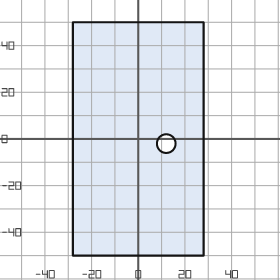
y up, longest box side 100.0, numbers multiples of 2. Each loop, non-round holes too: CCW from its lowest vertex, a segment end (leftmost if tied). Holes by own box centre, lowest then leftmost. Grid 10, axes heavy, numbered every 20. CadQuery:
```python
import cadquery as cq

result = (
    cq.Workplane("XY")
    .moveTo(-28.0, -50.0)
    .lineTo(28.0, -50.0)
    .lineTo(28.0, 50.0)
    .lineTo(-28.0, 50.0)
    .close()
    .moveTo(12.0, -2.0)
    .circle(4.0)
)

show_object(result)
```